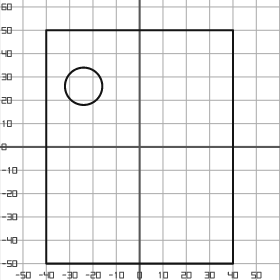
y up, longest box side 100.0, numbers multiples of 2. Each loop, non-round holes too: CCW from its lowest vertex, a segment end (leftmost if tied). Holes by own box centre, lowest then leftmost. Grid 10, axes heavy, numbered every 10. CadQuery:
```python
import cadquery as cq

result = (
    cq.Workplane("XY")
    .moveTo(-40.0, -50.0)
    .lineTo(40.0, -50.0)
    .lineTo(40.0, 50.0)
    .lineTo(-40.0, 50.0)
    .close()
    .moveTo(-24.0, 26.0)
    .circle(8.0)
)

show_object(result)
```